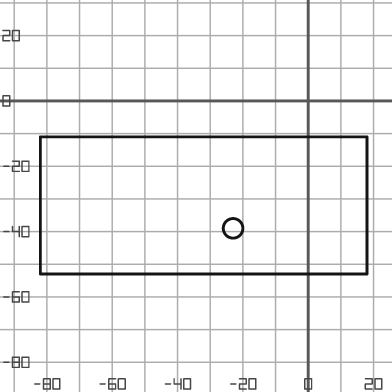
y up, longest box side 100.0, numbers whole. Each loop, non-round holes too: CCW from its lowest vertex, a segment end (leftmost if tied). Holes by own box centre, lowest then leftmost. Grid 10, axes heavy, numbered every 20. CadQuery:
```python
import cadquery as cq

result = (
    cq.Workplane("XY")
    .moveTo(-82.0, -53.0)
    .lineTo(18.0, -53.0)
    .lineTo(18.0, -11.0)
    .lineTo(-82.0, -11.0)
    .close()
    .moveTo(-23.0, -39.0)
    .circle(3.0)
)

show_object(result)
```